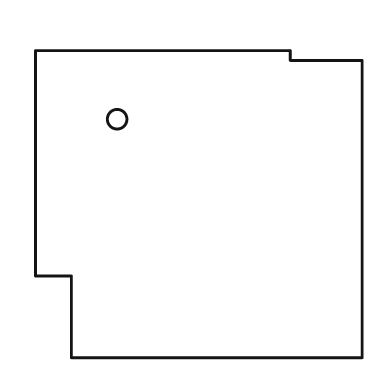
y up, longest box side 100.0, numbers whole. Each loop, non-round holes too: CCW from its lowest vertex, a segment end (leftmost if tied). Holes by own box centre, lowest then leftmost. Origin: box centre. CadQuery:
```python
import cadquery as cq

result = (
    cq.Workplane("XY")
    .moveTo(-39.0, -47.0)
    .lineTo(50.0, -47.0)
    .lineTo(50.0, 44.0)
    .lineTo(28.0, 44.0)
    .lineTo(28.0, 47.0)
    .lineTo(-50.0, 47.0)
    .lineTo(-50.0, -22.0)
    .lineTo(-39.0, -22.0)
    .close()
    .moveTo(-25.0, 26.0)
    .circle(3.0)
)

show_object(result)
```